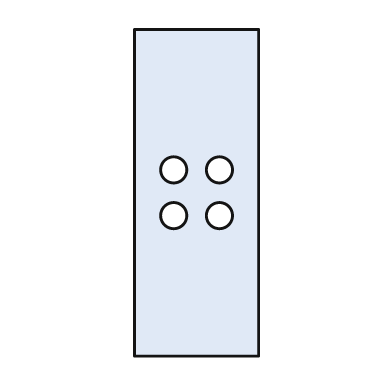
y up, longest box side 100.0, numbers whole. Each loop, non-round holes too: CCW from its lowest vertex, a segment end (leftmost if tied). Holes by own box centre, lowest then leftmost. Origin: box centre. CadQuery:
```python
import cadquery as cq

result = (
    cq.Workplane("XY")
    .moveTo(-19.0, -50.0)
    .lineTo(19.0, -50.0)
    .lineTo(19.0, 50.0)
    .lineTo(-19.0, 50.0)
    .close()
    .moveTo(-7.0, -7.0)
    .circle(4.0)
    .moveTo(7.0, -7.0)
    .circle(4.0)
    .moveTo(-7.0, 7.0)
    .circle(4.0)
    .moveTo(7.0, 7.0)
    .circle(4.0)
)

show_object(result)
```